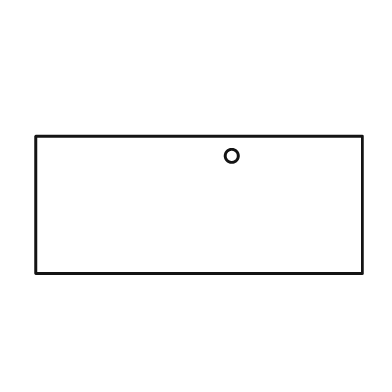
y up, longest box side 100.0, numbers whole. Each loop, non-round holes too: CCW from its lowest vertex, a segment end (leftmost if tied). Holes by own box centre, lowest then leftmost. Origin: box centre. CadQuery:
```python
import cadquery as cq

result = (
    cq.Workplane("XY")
    .moveTo(-50.0, -21.0)
    .lineTo(50.0, -21.0)
    .lineTo(50.0, 21.0)
    .lineTo(-50.0, 21.0)
    .close()
    .moveTo(10.0, 15.0)
    .circle(2.0)
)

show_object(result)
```